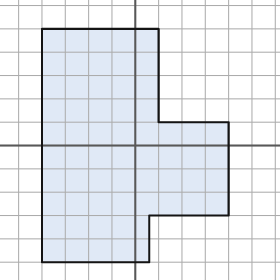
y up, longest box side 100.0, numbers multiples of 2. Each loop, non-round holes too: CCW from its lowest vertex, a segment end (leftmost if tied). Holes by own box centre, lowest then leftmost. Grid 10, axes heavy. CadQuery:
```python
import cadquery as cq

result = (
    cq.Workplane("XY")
    .moveTo(-40.0, -50.0)
    .lineTo(6.0, -50.0)
    .lineTo(6.0, -30.0)
    .lineTo(40.0, -30.0)
    .lineTo(40.0, 10.0)
    .lineTo(10.0, 10.0)
    .lineTo(10.0, 50.0)
    .lineTo(-40.0, 50.0)
    .close()
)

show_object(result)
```